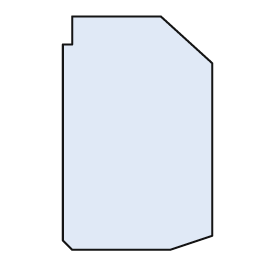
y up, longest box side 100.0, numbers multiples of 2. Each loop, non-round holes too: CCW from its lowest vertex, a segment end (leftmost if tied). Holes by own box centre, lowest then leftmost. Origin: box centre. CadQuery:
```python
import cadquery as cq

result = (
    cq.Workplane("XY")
    .moveTo(-28.0, -50.0)
    .lineTo(14.0, -50.0)
    .lineTo(32.0, -44.0)
    .lineTo(32.0, 30.0)
    .lineTo(10.0, 50.0)
    .lineTo(-28.0, 50.0)
    .lineTo(-28.0, 38.0)
    .lineTo(-32.0, 38.0)
    .lineTo(-32.0, -46.0)
    .close()
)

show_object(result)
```